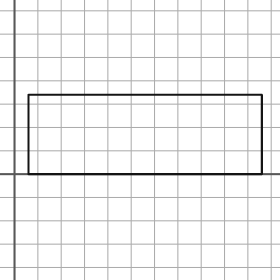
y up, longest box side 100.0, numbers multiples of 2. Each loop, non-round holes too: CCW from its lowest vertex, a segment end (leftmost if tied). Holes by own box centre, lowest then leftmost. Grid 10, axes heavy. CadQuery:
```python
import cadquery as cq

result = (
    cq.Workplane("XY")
    .moveTo(6.0, 0.0)
    .lineTo(106.0, 0.0)
    .lineTo(106.0, 34.0)
    .lineTo(6.0, 34.0)
    .close()
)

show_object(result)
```